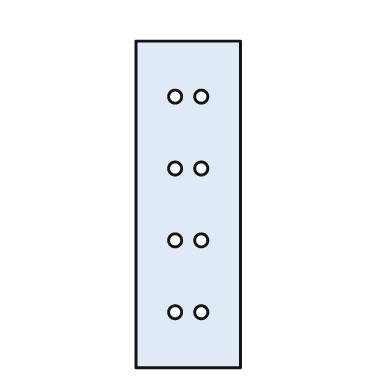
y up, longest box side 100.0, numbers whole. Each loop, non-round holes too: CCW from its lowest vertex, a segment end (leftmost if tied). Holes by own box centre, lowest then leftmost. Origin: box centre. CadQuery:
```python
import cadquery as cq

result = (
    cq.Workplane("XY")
    .moveTo(-16.0, -50.0)
    .lineTo(16.0, -50.0)
    .lineTo(16.0, 50.0)
    .lineTo(-16.0, 50.0)
    .close()
    .moveTo(-4.0, -33.0)
    .circle(2.0)
    .moveTo(4.0, -33.0)
    .circle(2.0)
    .moveTo(-4.0, -11.0)
    .circle(2.0)
    .moveTo(4.0, -11.0)
    .circle(2.0)
    .moveTo(-4.0, 11.0)
    .circle(2.0)
    .moveTo(4.0, 11.0)
    .circle(2.0)
    .moveTo(-4.0, 33.0)
    .circle(2.0)
    .moveTo(4.0, 33.0)
    .circle(2.0)
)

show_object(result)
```